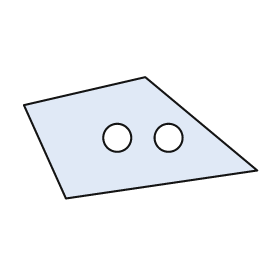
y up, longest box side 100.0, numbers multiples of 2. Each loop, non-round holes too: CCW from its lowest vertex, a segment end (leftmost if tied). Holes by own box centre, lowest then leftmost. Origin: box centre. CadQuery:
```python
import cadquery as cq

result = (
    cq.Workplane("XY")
    .moveTo(-32.0, -26.0)
    .lineTo(50.0, -14.0)
    .lineTo(2.0, 26.0)
    .lineTo(-50.0, 14.0)
    .close()
    .moveTo(-10.0, 0.0)
    .circle(6.0)
    .moveTo(12.0, 0.0)
    .circle(6.0)
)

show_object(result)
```